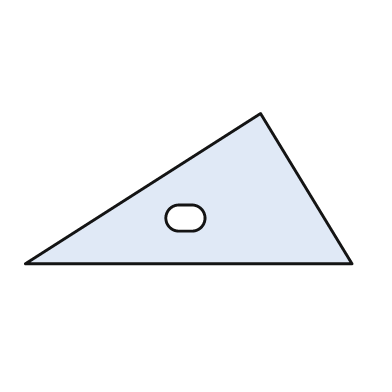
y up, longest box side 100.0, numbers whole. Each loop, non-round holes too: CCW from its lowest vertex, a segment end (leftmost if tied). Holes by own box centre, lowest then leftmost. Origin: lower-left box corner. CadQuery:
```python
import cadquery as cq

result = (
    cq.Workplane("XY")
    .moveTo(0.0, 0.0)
    .lineTo(100.0, 0.0)
    .lineTo(72.0, 46.0)
    .close()
    .moveTo(47.0, 10.0)
    .lineTo(51.0, 10.0)
    .threePointArc((55.0, 14.0), (51.0, 18.0))
    .lineTo(47.0, 18.0)
    .threePointArc((43.0, 14.0), (47.0, 10.0))
    .close()
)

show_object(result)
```